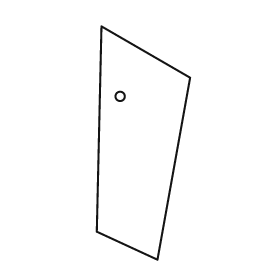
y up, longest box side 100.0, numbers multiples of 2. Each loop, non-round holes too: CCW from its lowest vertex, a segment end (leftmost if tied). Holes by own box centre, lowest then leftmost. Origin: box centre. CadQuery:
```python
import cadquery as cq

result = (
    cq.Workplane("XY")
    .moveTo(6.0, -50.0)
    .lineTo(20.0, 28.0)
    .lineTo(-18.0, 50.0)
    .lineTo(-20.0, -38.0)
    .close()
    .moveTo(-10.0, 20.0)
    .circle(2.0)
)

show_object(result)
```